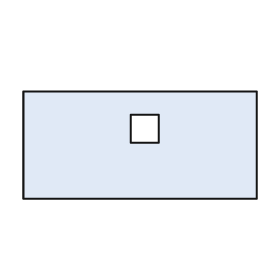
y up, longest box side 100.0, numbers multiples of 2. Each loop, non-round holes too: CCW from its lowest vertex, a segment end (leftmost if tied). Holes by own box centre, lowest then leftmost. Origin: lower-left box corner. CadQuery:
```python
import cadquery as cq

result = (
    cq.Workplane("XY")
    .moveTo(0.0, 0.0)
    .lineTo(100.0, 0.0)
    .lineTo(100.0, 46.0)
    .lineTo(0.0, 46.0)
    .close()
    .moveTo(46.0, 24.0)
    .lineTo(58.0, 24.0)
    .lineTo(58.0, 36.0)
    .lineTo(46.0, 36.0)
    .close()
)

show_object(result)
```